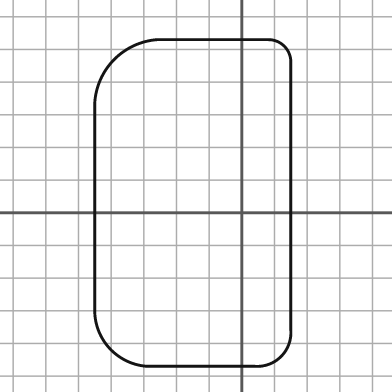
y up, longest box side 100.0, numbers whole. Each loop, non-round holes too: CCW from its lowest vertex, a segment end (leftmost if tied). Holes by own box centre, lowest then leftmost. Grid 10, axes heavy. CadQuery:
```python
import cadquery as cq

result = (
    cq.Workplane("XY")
    .moveTo(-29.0, -47.0)
    .lineTo(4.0, -47.0)
    .threePointArc((12.0, -44.0), (15.0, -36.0))
    .lineTo(15.0, 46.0)
    .threePointArc((13.0, 51.0), (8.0, 53.0))
    .lineTo(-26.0, 53.0)
    .threePointArc((-39.0, 47.0), (-45.0, 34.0))
    .lineTo(-45.0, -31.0)
    .threePointArc((-40.0, -42.0), (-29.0, -47.0))
    .close()
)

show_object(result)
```